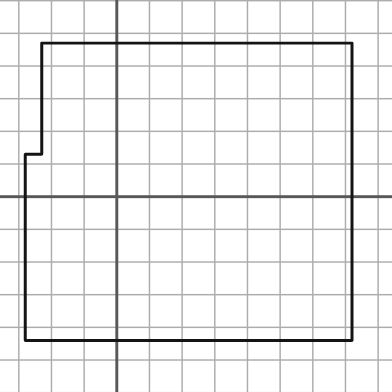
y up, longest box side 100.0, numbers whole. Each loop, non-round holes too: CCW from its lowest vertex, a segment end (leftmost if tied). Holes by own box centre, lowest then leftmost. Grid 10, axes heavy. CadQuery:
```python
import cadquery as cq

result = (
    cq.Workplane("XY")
    .moveTo(-28.0, -44.0)
    .lineTo(72.0, -44.0)
    .lineTo(72.0, 47.0)
    .lineTo(-23.0, 47.0)
    .lineTo(-23.0, 13.0)
    .lineTo(-28.0, 13.0)
    .close()
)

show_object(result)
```